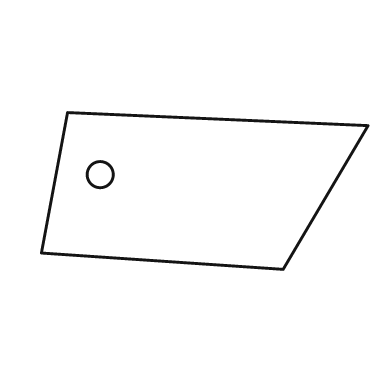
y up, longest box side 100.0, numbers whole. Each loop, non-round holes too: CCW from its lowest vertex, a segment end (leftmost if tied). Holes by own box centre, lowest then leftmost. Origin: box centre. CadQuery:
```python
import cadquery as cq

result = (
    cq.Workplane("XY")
    .moveTo(24.0, -24.0)
    .lineTo(50.0, 20.0)
    .lineTo(-42.0, 24.0)
    .lineTo(-50.0, -19.0)
    .close()
    .moveTo(-32.0, 5.0)
    .circle(4.0)
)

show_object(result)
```